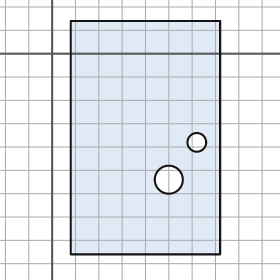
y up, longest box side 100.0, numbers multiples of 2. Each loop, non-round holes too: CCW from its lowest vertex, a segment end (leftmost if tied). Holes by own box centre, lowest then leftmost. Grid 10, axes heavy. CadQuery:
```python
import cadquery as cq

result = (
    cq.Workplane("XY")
    .moveTo(8.0, -86.0)
    .lineTo(72.0, -86.0)
    .lineTo(72.0, 14.0)
    .lineTo(8.0, 14.0)
    .close()
    .moveTo(50.0, -54.0)
    .circle(6.0)
    .moveTo(62.0, -38.0)
    .circle(4.0)
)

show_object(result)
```